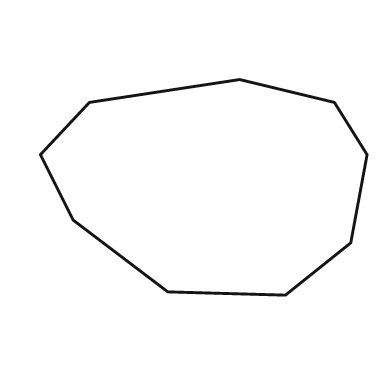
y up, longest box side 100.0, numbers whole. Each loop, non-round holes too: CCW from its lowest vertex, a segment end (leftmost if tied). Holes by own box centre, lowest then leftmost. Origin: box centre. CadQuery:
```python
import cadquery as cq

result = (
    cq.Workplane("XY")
    .moveTo(25.0, -33.0)
    .lineTo(45.0, -17.0)
    .lineTo(50.0, 10.0)
    .lineTo(40.0, 26.0)
    .lineTo(11.0, 33.0)
    .lineTo(-35.0, 26.0)
    .lineTo(-50.0, 10.0)
    .lineTo(-40.0, -10.0)
    .lineTo(-11.0, -32.0)
    .close()
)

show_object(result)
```